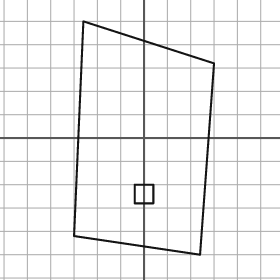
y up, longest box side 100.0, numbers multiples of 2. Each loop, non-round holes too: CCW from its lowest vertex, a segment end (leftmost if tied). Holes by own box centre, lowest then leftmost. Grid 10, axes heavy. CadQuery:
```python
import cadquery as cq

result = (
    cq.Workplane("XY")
    .moveTo(24.0, -50.0)
    .lineTo(30.0, 32.0)
    .lineTo(-26.0, 50.0)
    .lineTo(-30.0, -42.0)
    .close()
    .moveTo(-4.0, -28.0)
    .lineTo(4.0, -28.0)
    .lineTo(4.0, -20.0)
    .lineTo(-4.0, -20.0)
    .close()
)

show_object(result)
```